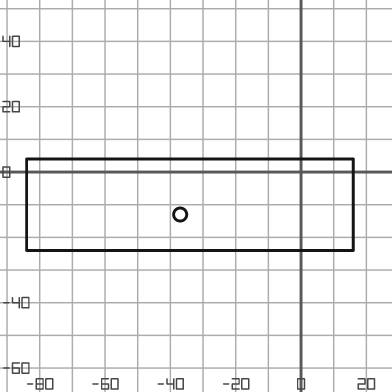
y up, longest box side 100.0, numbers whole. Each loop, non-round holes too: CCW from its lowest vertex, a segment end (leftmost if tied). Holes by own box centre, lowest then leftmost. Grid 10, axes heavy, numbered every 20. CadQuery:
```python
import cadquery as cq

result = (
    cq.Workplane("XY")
    .moveTo(-84.0, -24.0)
    .lineTo(16.0, -24.0)
    .lineTo(16.0, 4.0)
    .lineTo(-84.0, 4.0)
    .close()
    .moveTo(-37.0, -13.0)
    .circle(2.0)
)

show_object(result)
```